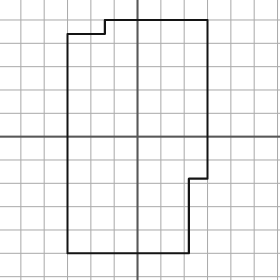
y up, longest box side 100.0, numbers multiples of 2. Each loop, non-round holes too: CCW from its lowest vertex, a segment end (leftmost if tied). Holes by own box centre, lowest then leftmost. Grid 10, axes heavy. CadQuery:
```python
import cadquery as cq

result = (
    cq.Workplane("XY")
    .moveTo(-30.0, -50.0)
    .lineTo(22.0, -50.0)
    .lineTo(22.0, -18.0)
    .lineTo(30.0, -18.0)
    .lineTo(30.0, 50.0)
    .lineTo(-14.0, 50.0)
    .lineTo(-14.0, 44.0)
    .lineTo(-30.0, 44.0)
    .close()
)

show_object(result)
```